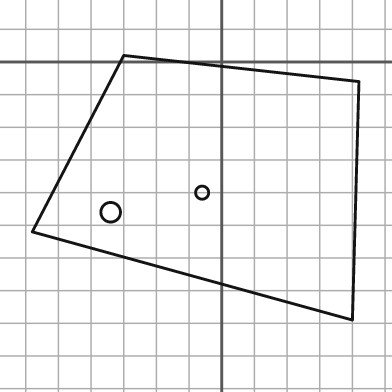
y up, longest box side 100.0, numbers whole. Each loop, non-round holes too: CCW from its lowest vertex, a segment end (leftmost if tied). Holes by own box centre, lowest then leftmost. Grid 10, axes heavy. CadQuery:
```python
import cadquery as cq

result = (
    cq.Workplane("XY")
    .moveTo(40.0, -79.0)
    .lineTo(42.0, -6.0)
    .lineTo(-30.0, 2.0)
    .lineTo(-58.0, -52.0)
    .close()
    .moveTo(-34.0, -46.0)
    .circle(3.0)
    .moveTo(-6.0, -40.0)
    .circle(2.0)
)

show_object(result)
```